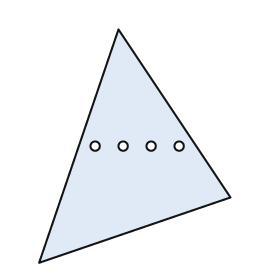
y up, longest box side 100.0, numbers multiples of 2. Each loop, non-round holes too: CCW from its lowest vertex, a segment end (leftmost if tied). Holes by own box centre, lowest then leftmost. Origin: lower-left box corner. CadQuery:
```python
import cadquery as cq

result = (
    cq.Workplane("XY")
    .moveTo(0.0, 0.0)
    .lineTo(82.0, 28.0)
    .lineTo(34.0, 100.0)
    .close()
    .moveTo(24.0, 50.0)
    .circle(2.0)
    .moveTo(36.0, 50.0)
    .circle(2.0)
    .moveTo(48.0, 50.0)
    .circle(2.0)
    .moveTo(60.0, 50.0)
    .circle(2.0)
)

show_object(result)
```